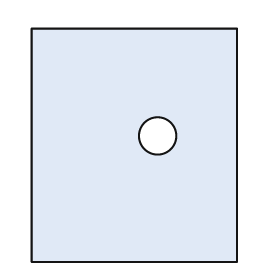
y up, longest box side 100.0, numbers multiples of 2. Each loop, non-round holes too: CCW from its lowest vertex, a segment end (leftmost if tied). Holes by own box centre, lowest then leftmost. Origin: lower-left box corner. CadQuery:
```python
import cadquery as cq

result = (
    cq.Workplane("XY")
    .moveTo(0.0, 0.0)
    .lineTo(88.0, 0.0)
    .lineTo(88.0, 100.0)
    .lineTo(0.0, 100.0)
    .close()
    .moveTo(54.0, 54.0)
    .circle(8.0)
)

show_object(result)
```